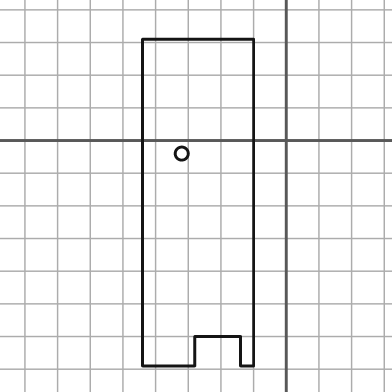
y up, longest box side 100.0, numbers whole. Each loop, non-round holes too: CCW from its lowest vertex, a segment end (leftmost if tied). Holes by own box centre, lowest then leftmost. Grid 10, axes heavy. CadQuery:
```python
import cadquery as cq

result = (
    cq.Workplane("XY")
    .moveTo(-44.0, -69.0)
    .lineTo(-28.0, -69.0)
    .lineTo(-28.0, -60.0)
    .lineTo(-14.0, -60.0)
    .lineTo(-14.0, -69.0)
    .lineTo(-10.0, -69.0)
    .lineTo(-10.0, 31.0)
    .lineTo(-44.0, 31.0)
    .close()
    .moveTo(-32.0, -4.0)
    .circle(2.0)
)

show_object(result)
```